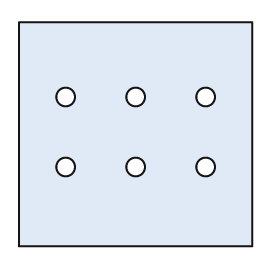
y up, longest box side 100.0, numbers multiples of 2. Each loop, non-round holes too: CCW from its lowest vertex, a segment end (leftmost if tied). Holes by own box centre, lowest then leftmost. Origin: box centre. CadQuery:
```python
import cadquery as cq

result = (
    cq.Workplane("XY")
    .moveTo(-50.0, -48.0)
    .lineTo(50.0, -48.0)
    .lineTo(50.0, 48.0)
    .lineTo(-50.0, 48.0)
    .close()
    .moveTo(-30.0, -14.0)
    .circle(4.0)
    .moveTo(0.0, -14.0)
    .circle(4.0)
    .moveTo(30.0, -14.0)
    .circle(4.0)
    .moveTo(-30.0, 16.0)
    .circle(4.0)
    .moveTo(0.0, 16.0)
    .circle(4.0)
    .moveTo(30.0, 16.0)
    .circle(4.0)
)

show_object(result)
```